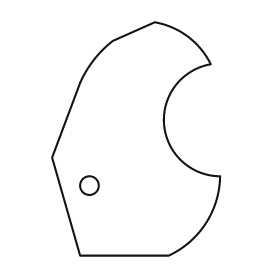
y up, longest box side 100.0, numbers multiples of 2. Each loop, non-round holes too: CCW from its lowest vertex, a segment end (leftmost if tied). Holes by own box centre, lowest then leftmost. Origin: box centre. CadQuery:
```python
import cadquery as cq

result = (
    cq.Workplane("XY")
    .moveTo(-24.0, -50.0)
    .lineTo(14.0, -50.0)
    .threePointArc((30.0, -36.0), (36.0, -16.0))
    .threePointArc((12.0, 6.0), (32.0, 32.0))
    .threePointArc((22.0, 44.0), (8.0, 50.0))
    .lineTo(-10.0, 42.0)
    .threePointArc((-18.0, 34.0), (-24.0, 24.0))
    .lineTo(-36.0, -8.0)
    .close()
    .moveTo(-20.0, -20.0)
    .circle(4.0)
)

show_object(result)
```